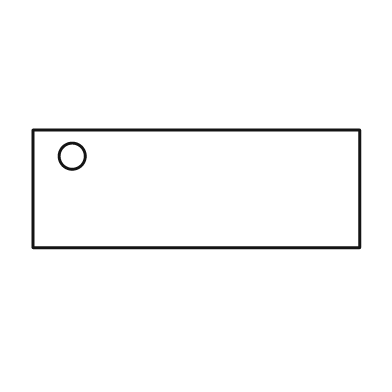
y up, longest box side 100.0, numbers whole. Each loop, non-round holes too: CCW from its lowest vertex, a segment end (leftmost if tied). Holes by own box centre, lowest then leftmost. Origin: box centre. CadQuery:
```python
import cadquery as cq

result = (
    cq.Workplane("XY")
    .moveTo(-50.0, -18.0)
    .lineTo(50.0, -18.0)
    .lineTo(50.0, 18.0)
    .lineTo(-50.0, 18.0)
    .close()
    .moveTo(-38.0, 10.0)
    .circle(4.0)
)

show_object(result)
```